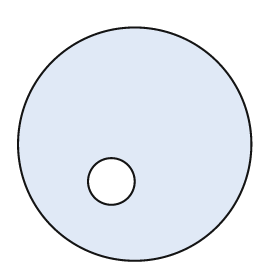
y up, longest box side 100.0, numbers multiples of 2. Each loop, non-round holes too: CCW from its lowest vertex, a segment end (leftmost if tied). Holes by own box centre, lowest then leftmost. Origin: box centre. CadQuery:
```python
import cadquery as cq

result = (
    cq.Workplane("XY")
    .moveTo(0.0, 0.0)
    .circle(50.0)
    .moveTo(-10.0, -16.0)
    .circle(10.0)
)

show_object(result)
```